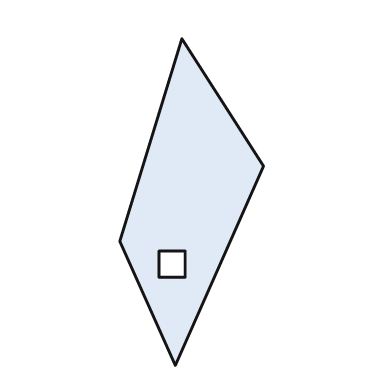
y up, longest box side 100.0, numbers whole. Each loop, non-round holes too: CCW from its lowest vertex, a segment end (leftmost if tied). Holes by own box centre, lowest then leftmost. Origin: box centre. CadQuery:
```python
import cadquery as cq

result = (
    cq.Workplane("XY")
    .moveTo(-5.0, -50.0)
    .lineTo(22.0, 11.0)
    .lineTo(-3.0, 50.0)
    .lineTo(-22.0, -12.0)
    .close()
    .moveTo(-10.0, -23.0)
    .lineTo(-2.0, -23.0)
    .lineTo(-2.0, -15.0)
    .lineTo(-10.0, -15.0)
    .close()
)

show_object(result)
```